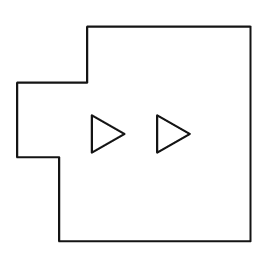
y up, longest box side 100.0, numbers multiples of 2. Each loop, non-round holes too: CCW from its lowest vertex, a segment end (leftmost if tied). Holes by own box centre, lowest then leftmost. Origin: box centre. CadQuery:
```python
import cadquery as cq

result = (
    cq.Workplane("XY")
    .moveTo(-32.0, -46.0)
    .lineTo(50.0, -46.0)
    .lineTo(50.0, 46.0)
    .lineTo(-20.0, 46.0)
    .lineTo(-20.0, 22.0)
    .lineTo(-50.0, 22.0)
    .lineTo(-50.0, -10.0)
    .lineTo(-32.0, -10.0)
    .close()
    .moveTo(-18.0, -8.0)
    .lineTo(-4.0, 0.0)
    .lineTo(-18.0, 8.0)
    .close()
    .moveTo(10.0, -8.0)
    .lineTo(24.0, 0.0)
    .lineTo(10.0, 8.0)
    .close()
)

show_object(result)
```